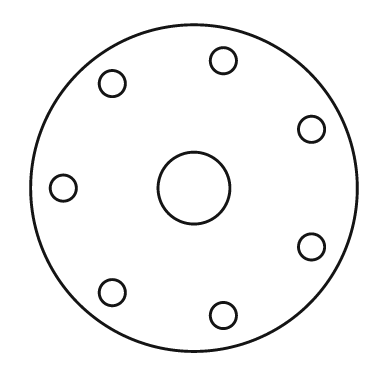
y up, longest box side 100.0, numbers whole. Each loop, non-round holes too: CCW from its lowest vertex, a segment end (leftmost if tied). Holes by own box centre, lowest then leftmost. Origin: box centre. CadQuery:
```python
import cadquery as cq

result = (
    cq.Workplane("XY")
    .moveTo(0.0, 0.0)
    .circle(50.0)
    .moveTo(9.0, -39.0)
    .circle(4.0)
    .moveTo(-25.0, -32.0)
    .circle(4.0)
    .moveTo(36.0, -18.0)
    .circle(4.0)
    .moveTo(-40.0, 0.0)
    .circle(4.0)
    .moveTo(0.0, 0.0)
    .circle(11.0)
    .moveTo(36.0, 18.0)
    .circle(4.0)
    .moveTo(-25.0, 32.0)
    .circle(4.0)
    .moveTo(9.0, 39.0)
    .circle(4.0)
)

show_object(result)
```